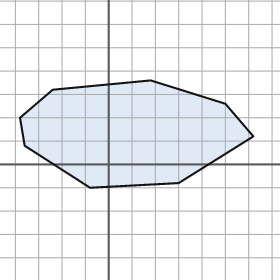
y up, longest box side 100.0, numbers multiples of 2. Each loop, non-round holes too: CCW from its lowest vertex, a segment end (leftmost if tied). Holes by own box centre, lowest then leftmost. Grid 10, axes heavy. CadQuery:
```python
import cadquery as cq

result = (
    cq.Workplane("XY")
    .moveTo(-8.0, -10.0)
    .lineTo(30.0, -8.0)
    .lineTo(62.0, 12.0)
    .lineTo(50.0, 26.0)
    .lineTo(18.0, 36.0)
    .lineTo(-24.0, 32.0)
    .lineTo(-38.0, 20.0)
    .lineTo(-36.0, 8.0)
    .close()
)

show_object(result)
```